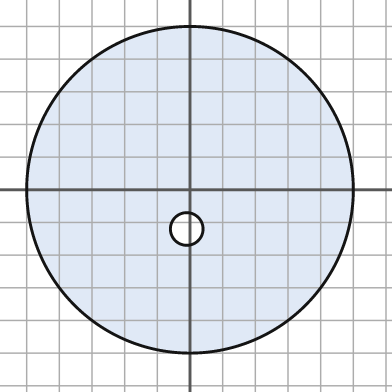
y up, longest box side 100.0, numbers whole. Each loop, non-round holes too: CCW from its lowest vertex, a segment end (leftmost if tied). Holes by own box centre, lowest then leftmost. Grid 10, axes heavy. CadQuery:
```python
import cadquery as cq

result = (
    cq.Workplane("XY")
    .moveTo(0.0, 0.0)
    .circle(50.0)
    .moveTo(-1.0, -12.0)
    .circle(5.0)
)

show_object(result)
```